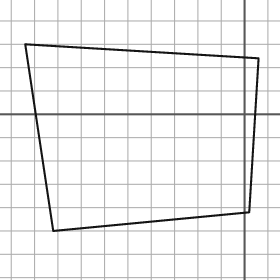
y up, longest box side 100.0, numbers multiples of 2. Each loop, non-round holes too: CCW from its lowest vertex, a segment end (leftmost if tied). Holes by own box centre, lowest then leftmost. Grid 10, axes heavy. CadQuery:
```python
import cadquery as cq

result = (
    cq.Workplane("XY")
    .moveTo(-82.0, -50.0)
    .lineTo(2.0, -42.0)
    .lineTo(6.0, 24.0)
    .lineTo(-94.0, 30.0)
    .close()
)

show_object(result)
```